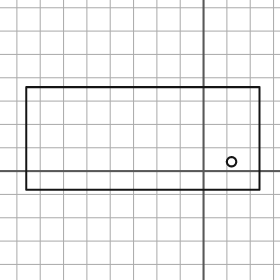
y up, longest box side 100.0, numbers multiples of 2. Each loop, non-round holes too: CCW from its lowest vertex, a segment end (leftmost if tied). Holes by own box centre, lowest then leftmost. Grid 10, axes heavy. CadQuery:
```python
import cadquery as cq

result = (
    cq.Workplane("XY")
    .moveTo(-76.0, -8.0)
    .lineTo(24.0, -8.0)
    .lineTo(24.0, 36.0)
    .lineTo(-76.0, 36.0)
    .close()
    .moveTo(12.0, 4.0)
    .circle(2.0)
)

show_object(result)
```